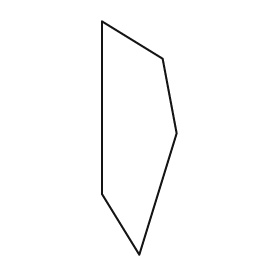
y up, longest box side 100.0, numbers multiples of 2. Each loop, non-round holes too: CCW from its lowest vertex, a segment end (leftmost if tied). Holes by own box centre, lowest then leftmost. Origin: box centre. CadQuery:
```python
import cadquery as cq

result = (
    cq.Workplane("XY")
    .moveTo(0.0, -50.0)
    .lineTo(16.0, 2.0)
    .lineTo(10.0, 34.0)
    .lineTo(-16.0, 50.0)
    .lineTo(-16.0, -24.0)
    .close()
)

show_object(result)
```